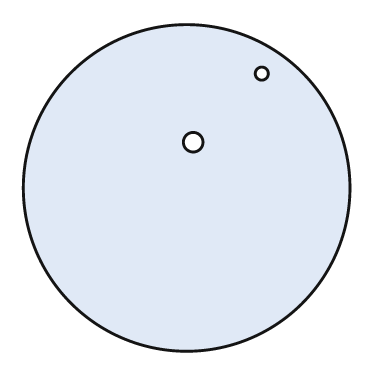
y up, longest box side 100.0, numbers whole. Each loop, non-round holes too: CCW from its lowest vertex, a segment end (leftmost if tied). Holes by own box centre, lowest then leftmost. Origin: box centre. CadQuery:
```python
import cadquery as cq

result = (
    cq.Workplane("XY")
    .moveTo(0.0, 0.0)
    .circle(50.0)
    .moveTo(2.0, 14.0)
    .circle(3.0)
    .moveTo(23.0, 35.0)
    .circle(2.0)
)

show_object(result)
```